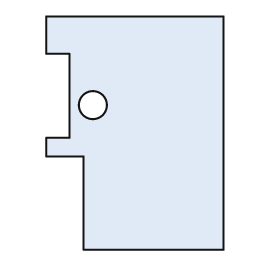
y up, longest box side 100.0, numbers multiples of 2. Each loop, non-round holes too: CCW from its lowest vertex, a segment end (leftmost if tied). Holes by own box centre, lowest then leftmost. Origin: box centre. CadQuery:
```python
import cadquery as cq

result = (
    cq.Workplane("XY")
    .moveTo(-22.0, -50.0)
    .lineTo(38.0, -50.0)
    .lineTo(38.0, 50.0)
    .lineTo(-38.0, 50.0)
    .lineTo(-38.0, 34.0)
    .lineTo(-28.0, 34.0)
    .lineTo(-28.0, -2.0)
    .lineTo(-38.0, -2.0)
    .lineTo(-38.0, -10.0)
    .lineTo(-22.0, -10.0)
    .close()
    .moveTo(-18.0, 12.0)
    .circle(6.0)
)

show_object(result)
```